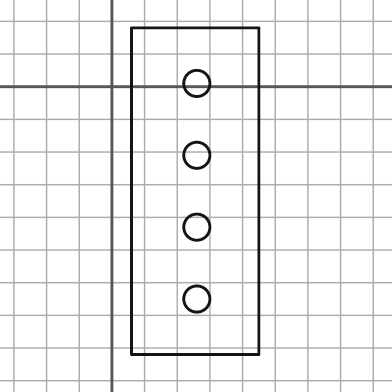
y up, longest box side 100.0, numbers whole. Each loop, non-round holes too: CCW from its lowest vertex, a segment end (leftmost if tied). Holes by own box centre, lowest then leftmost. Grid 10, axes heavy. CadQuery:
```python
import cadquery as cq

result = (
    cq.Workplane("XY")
    .moveTo(6.0, -82.0)
    .lineTo(45.0, -82.0)
    .lineTo(45.0, 18.0)
    .lineTo(6.0, 18.0)
    .close()
    .moveTo(26.0, -65.0)
    .circle(4.0)
    .moveTo(26.0, -43.0)
    .circle(4.0)
    .moveTo(26.0, -21.0)
    .circle(4.0)
    .moveTo(26.0, 1.0)
    .circle(4.0)
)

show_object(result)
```